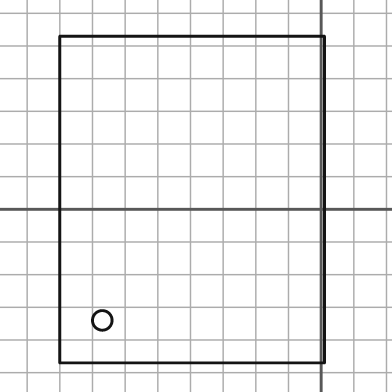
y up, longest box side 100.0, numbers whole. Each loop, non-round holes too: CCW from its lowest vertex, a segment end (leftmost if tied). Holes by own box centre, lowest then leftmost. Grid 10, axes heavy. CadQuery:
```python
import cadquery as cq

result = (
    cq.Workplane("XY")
    .moveTo(-80.0, -47.0)
    .lineTo(1.0, -47.0)
    .lineTo(1.0, 53.0)
    .lineTo(-80.0, 53.0)
    .close()
    .moveTo(-67.0, -34.0)
    .circle(3.0)
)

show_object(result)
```